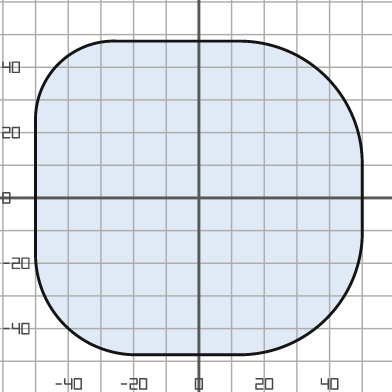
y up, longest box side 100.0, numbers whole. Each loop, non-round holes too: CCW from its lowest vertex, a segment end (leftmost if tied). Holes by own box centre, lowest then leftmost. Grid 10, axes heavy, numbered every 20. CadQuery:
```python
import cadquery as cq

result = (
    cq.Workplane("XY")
    .moveTo(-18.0, -48.0)
    .lineTo(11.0, -48.0)
    .threePointArc((39.0, -37.0), (50.0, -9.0))
    .lineTo(50.0, 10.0)
    .threePointArc((39.0, 37.0), (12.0, 48.0))
    .lineTo(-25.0, 48.0)
    .threePointArc((-43.0, 41.0), (-50.0, 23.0))
    .lineTo(-50.0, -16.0)
    .threePointArc((-41.0, -39.0), (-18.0, -48.0))
    .close()
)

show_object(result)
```